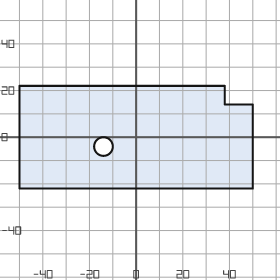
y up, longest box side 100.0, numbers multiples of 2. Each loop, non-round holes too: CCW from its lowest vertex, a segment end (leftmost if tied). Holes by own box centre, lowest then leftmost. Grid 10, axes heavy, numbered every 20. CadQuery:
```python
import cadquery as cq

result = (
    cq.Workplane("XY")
    .moveTo(-50.0, -22.0)
    .lineTo(50.0, -22.0)
    .lineTo(50.0, 14.0)
    .lineTo(38.0, 14.0)
    .lineTo(38.0, 22.0)
    .lineTo(-50.0, 22.0)
    .close()
    .moveTo(-14.0, -4.0)
    .circle(4.0)
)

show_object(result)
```